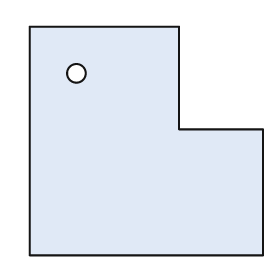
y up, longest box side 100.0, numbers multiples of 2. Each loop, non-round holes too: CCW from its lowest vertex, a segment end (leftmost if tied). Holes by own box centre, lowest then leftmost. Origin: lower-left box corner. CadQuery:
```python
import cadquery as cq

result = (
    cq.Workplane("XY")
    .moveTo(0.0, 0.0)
    .lineTo(100.0, 0.0)
    .lineTo(100.0, 54.0)
    .lineTo(64.0, 54.0)
    .lineTo(64.0, 98.0)
    .lineTo(0.0, 98.0)
    .close()
    .moveTo(20.0, 78.0)
    .circle(4.0)
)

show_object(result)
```